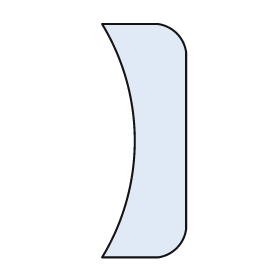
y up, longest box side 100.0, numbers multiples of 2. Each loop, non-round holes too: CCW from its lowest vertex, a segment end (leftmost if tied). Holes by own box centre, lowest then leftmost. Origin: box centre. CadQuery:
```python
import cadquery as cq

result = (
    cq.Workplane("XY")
    .moveTo(-18.0, -50.0)
    .lineTo(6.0, -50.0)
    .threePointArc((14.0, -46.0), (18.0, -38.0))
    .lineTo(18.0, 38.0)
    .threePointArc((14.0, 46.0), (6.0, 50.0))
    .lineTo(-18.0, 50.0)
    .threePointArc((-4.0, 0.0), (-18.0, -50.0))
    .close()
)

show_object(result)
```